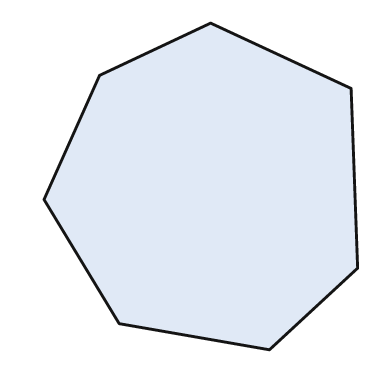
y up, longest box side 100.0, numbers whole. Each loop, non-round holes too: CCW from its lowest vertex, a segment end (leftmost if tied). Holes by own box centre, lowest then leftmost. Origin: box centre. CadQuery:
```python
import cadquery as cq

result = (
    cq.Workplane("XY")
    .moveTo(21.0, -50.0)
    .lineTo(48.0, -25.0)
    .lineTo(46.0, 30.0)
    .lineTo(3.0, 50.0)
    .lineTo(-31.0, 34.0)
    .lineTo(-48.0, -4.0)
    .lineTo(-25.0, -42.0)
    .close()
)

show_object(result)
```